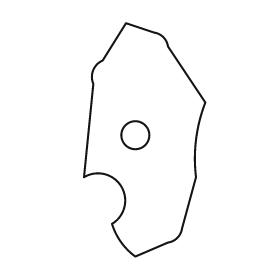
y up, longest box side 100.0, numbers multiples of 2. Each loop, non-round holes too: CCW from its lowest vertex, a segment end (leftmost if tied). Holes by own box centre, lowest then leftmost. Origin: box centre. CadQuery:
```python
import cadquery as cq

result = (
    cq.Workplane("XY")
    .moveTo(-4.0, -50.0)
    .lineTo(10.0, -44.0)
    .threePointArc((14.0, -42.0), (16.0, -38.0))
    .lineTo(22.0, -16.0)
    .threePointArc((22.0, 0.0), (26.0, 16.0))
    .lineTo(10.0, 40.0)
    .threePointArc((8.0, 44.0), (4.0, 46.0))
    .lineTo(-8.0, 50.0)
    .lineTo(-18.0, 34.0)
    .threePointArc((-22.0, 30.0), (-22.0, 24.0))
    .lineTo(-26.0, -16.0)
    .threePointArc((-10.0, -20.0), (-14.0, -36.0))
    .threePointArc((-10.0, -44.0), (-4.0, -50.0))
    .close()
    .moveTo(-4.0, 2.0)
    .circle(6.0)
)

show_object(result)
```